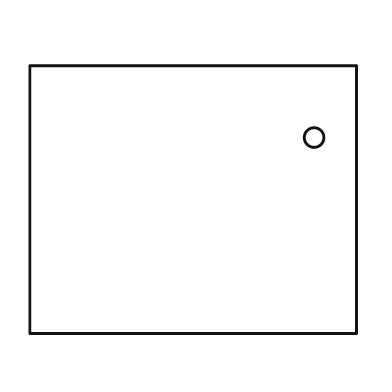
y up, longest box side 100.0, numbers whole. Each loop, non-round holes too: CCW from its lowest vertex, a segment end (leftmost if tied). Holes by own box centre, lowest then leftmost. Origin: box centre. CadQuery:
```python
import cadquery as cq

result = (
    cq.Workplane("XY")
    .moveTo(-50.0, -41.0)
    .lineTo(50.0, -41.0)
    .lineTo(50.0, 41.0)
    .lineTo(-50.0, 41.0)
    .close()
    .moveTo(37.0, 19.0)
    .circle(3.0)
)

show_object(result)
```